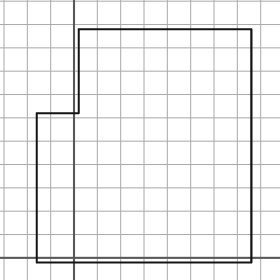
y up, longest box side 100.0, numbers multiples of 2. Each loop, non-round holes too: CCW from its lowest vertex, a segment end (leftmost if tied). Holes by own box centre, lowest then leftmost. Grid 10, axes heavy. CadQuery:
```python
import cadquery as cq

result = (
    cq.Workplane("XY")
    .moveTo(-16.0, -2.0)
    .lineTo(76.0, -2.0)
    .lineTo(76.0, 98.0)
    .lineTo(2.0, 98.0)
    .lineTo(2.0, 62.0)
    .lineTo(-16.0, 62.0)
    .close()
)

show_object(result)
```